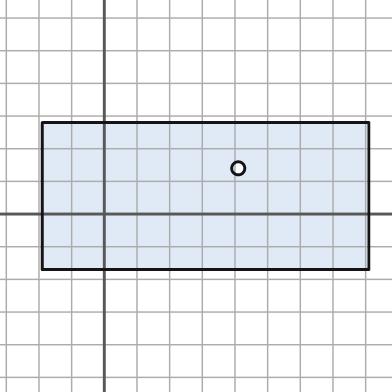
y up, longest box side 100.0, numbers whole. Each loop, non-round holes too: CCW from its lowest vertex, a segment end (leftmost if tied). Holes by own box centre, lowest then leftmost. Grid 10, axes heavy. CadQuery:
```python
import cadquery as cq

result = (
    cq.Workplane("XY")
    .moveTo(-19.0, -17.0)
    .lineTo(81.0, -17.0)
    .lineTo(81.0, 28.0)
    .lineTo(-19.0, 28.0)
    .close()
    .moveTo(41.0, 14.0)
    .circle(2.0)
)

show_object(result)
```